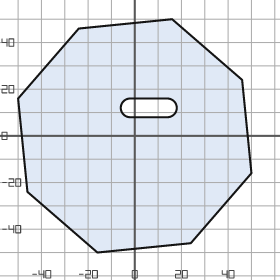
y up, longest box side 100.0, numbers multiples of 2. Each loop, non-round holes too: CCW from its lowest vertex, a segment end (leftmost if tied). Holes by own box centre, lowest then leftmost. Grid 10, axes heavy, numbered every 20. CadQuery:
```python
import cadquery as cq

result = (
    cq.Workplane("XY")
    .moveTo(-16.0, -50.0)
    .lineTo(24.0, -46.0)
    .lineTo(50.0, -16.0)
    .lineTo(46.0, 24.0)
    .lineTo(16.0, 50.0)
    .lineTo(-24.0, 46.0)
    .lineTo(-50.0, 16.0)
    .lineTo(-46.0, -24.0)
    .close()
    .moveTo(-2.0, 8.0)
    .lineTo(14.0, 8.0)
    .threePointArc((18.0, 12.0), (14.0, 16.0))
    .lineTo(-2.0, 16.0)
    .threePointArc((-6.0, 12.0), (-2.0, 8.0))
    .close()
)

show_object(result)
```